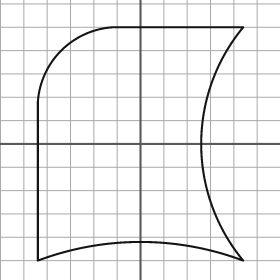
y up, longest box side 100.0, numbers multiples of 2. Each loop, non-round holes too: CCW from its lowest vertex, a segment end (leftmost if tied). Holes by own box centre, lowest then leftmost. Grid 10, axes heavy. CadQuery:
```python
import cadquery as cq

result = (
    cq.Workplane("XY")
    .moveTo(-44.0, -50.0)
    .threePointArc((0.0, -42.0), (44.0, -50.0))
    .threePointArc((26.0, 0.0), (44.0, 50.0))
    .lineTo(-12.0, 50.0)
    .threePointArc((-34.0, 40.0), (-44.0, 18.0))
    .close()
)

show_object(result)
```